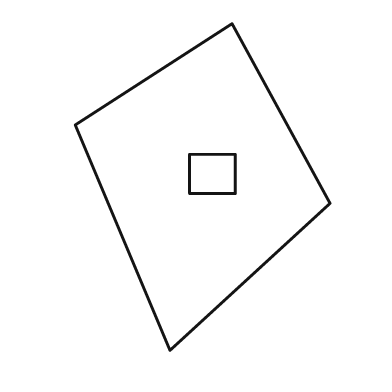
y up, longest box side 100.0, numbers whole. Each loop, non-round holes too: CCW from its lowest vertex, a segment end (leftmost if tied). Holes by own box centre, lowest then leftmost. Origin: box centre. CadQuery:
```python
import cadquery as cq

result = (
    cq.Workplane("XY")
    .moveTo(-10.0, -50.0)
    .lineTo(39.0, -5.0)
    .lineTo(9.0, 50.0)
    .lineTo(-39.0, 19.0)
    .close()
    .moveTo(-4.0, -2.0)
    .lineTo(10.0, -2.0)
    .lineTo(10.0, 10.0)
    .lineTo(-4.0, 10.0)
    .close()
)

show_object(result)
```